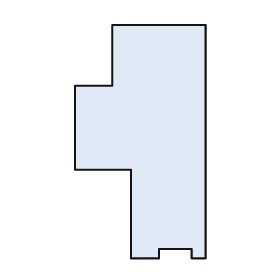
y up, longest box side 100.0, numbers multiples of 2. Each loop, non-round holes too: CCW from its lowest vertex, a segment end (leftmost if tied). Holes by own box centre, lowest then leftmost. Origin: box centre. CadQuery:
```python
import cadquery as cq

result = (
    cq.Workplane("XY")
    .moveTo(-4.0, -50.0)
    .lineTo(8.0, -50.0)
    .lineTo(8.0, -46.0)
    .lineTo(22.0, -46.0)
    .lineTo(22.0, -50.0)
    .lineTo(28.0, -50.0)
    .lineTo(28.0, 50.0)
    .lineTo(-12.0, 50.0)
    .lineTo(-12.0, 24.0)
    .lineTo(-28.0, 24.0)
    .lineTo(-28.0, -12.0)
    .lineTo(-4.0, -12.0)
    .close()
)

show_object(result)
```